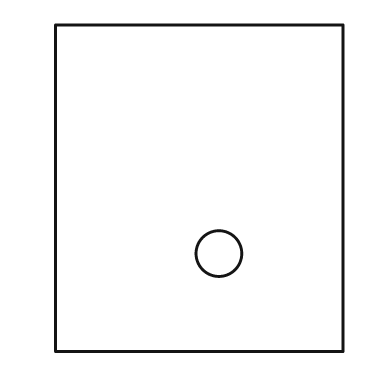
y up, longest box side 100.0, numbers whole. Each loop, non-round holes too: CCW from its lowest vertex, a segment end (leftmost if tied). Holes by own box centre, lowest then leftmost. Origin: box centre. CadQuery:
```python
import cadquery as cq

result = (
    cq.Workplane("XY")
    .moveTo(-44.0, -50.0)
    .lineTo(44.0, -50.0)
    .lineTo(44.0, 50.0)
    .lineTo(-44.0, 50.0)
    .close()
    .moveTo(6.0, -20.0)
    .circle(7.0)
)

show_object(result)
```